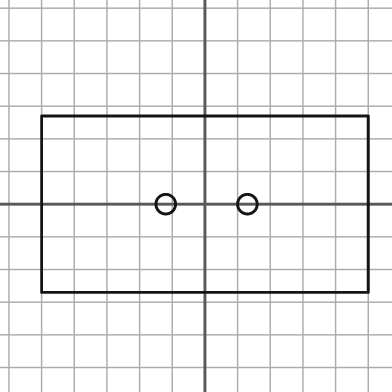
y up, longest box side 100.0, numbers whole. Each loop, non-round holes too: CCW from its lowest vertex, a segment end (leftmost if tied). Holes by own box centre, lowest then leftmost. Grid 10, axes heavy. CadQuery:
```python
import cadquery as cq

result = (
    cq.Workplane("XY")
    .moveTo(-50.0, -27.0)
    .lineTo(50.0, -27.0)
    .lineTo(50.0, 27.0)
    .lineTo(-50.0, 27.0)
    .close()
    .moveTo(-12.0, 0.0)
    .circle(3.0)
    .moveTo(13.0, 0.0)
    .circle(3.0)
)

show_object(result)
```